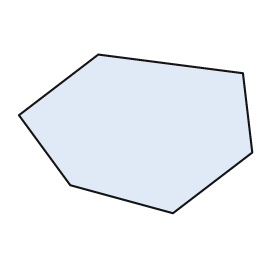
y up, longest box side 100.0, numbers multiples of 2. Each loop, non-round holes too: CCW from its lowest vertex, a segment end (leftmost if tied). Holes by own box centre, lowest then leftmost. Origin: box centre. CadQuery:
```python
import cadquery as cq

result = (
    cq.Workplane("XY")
    .moveTo(16.0, -34.0)
    .lineTo(50.0, -8.0)
    .lineTo(46.0, 26.0)
    .lineTo(-16.0, 34.0)
    .lineTo(-50.0, 8.0)
    .lineTo(-28.0, -22.0)
    .close()
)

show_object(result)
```